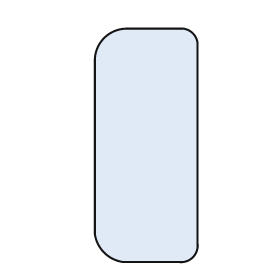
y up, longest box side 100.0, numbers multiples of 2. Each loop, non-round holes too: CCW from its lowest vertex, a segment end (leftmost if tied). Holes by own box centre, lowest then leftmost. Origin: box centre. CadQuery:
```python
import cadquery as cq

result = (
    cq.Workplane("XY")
    .moveTo(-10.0, -50.0)
    .lineTo(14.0, -50.0)
    .threePointArc((20.0, -48.0), (22.0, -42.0))
    .lineTo(22.0, 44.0)
    .threePointArc((20.0, 48.0), (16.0, 50.0))
    .lineTo(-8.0, 50.0)
    .threePointArc((-18.0, 46.0), (-22.0, 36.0))
    .lineTo(-22.0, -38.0)
    .threePointArc((-18.0, -46.0), (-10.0, -50.0))
    .close()
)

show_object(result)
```